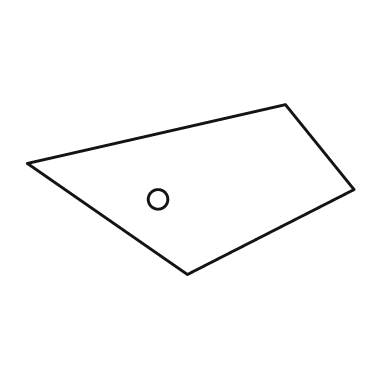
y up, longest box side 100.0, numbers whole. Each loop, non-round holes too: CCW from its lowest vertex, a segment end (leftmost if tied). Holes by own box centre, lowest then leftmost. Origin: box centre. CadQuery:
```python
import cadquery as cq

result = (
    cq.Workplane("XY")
    .moveTo(-1.0, -26.0)
    .lineTo(50.0, 0.0)
    .lineTo(29.0, 26.0)
    .lineTo(-50.0, 8.0)
    .close()
    .moveTo(-10.0, -3.0)
    .circle(3.0)
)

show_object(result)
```